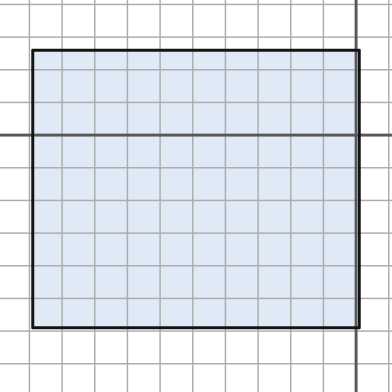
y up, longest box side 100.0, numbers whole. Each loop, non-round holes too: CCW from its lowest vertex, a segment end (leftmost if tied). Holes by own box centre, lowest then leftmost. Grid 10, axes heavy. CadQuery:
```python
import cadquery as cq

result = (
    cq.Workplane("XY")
    .moveTo(-99.0, -59.0)
    .lineTo(1.0, -59.0)
    .lineTo(1.0, 26.0)
    .lineTo(-99.0, 26.0)
    .close()
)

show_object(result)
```